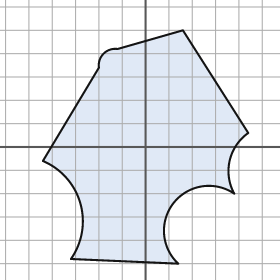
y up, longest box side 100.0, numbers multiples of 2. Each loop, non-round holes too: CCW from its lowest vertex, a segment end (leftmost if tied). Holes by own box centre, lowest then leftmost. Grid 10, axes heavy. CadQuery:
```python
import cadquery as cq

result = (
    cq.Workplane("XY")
    .moveTo(14.0, -50.0)
    .threePointArc((12.0, -24.0), (38.0, -20.0))
    .threePointArc((36.0, -6.0), (44.0, 6.0))
    .lineTo(16.0, 50.0)
    .lineTo(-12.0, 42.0)
    .threePointArc((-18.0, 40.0), (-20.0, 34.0))
    .lineTo(-44.0, -6.0)
    .threePointArc((-28.0, -24.0), (-32.0, -48.0))
    .close()
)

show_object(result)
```